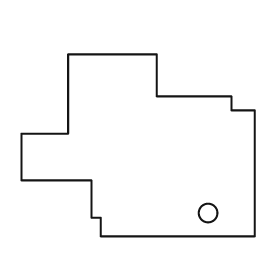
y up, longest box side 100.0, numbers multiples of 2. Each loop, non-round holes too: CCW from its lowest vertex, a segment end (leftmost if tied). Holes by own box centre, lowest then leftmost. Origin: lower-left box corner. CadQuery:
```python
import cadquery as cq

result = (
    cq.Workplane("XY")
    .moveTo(34.0, 0.0)
    .lineTo(100.0, 0.0)
    .lineTo(100.0, 54.0)
    .lineTo(90.0, 54.0)
    .lineTo(90.0, 60.0)
    .lineTo(58.0, 60.0)
    .lineTo(58.0, 78.0)
    .lineTo(20.0, 78.0)
    .lineTo(20.0, 44.0)
    .lineTo(0.0, 44.0)
    .lineTo(0.0, 24.0)
    .lineTo(30.0, 24.0)
    .lineTo(30.0, 8.0)
    .lineTo(34.0, 8.0)
    .close()
    .moveTo(80.0, 10.0)
    .circle(4.0)
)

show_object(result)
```